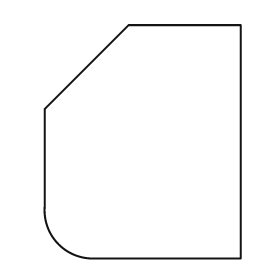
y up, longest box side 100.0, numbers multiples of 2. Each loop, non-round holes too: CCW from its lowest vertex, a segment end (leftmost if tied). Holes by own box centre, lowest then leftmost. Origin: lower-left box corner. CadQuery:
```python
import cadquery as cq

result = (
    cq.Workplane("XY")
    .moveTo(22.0, 0.0)
    .lineTo(84.0, 0.0)
    .lineTo(84.0, 100.0)
    .lineTo(36.0, 100.0)
    .lineTo(0.0, 64.0)
    .lineTo(0.0, 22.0)
    .threePointArc((6.0, 6.0), (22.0, 0.0))
    .close()
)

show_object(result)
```